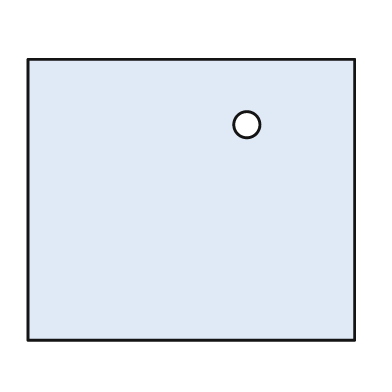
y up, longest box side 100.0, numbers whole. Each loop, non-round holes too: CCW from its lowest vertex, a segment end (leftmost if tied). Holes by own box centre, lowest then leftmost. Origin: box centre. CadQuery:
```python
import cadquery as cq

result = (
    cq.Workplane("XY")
    .moveTo(-50.0, -43.0)
    .lineTo(50.0, -43.0)
    .lineTo(50.0, 43.0)
    .lineTo(-50.0, 43.0)
    .close()
    .moveTo(17.0, 23.0)
    .circle(4.0)
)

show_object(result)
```